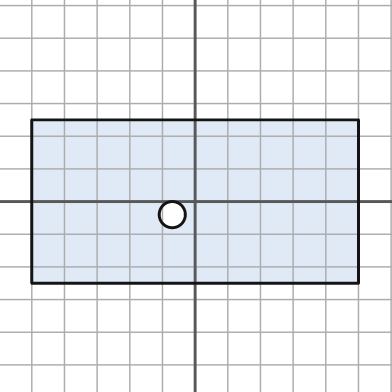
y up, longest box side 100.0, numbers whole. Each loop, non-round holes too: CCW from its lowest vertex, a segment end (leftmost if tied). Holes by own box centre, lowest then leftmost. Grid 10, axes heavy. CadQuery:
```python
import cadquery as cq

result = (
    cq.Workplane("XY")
    .moveTo(-50.0, -25.0)
    .lineTo(50.0, -25.0)
    .lineTo(50.0, 25.0)
    .lineTo(-50.0, 25.0)
    .close()
    .moveTo(-7.0, -4.0)
    .circle(4.0)
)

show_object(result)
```